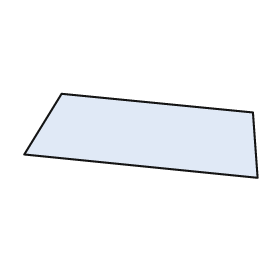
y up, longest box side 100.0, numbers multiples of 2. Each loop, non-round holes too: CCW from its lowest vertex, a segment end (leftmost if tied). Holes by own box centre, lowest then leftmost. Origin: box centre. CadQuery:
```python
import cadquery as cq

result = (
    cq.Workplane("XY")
    .moveTo(50.0, -18.0)
    .lineTo(48.0, 10.0)
    .lineTo(-34.0, 18.0)
    .lineTo(-50.0, -8.0)
    .close()
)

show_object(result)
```